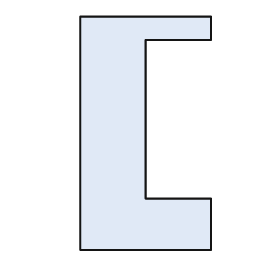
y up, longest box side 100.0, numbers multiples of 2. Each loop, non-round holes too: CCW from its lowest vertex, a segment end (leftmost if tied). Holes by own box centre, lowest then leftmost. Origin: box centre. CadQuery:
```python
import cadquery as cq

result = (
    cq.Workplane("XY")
    .moveTo(-28.0, -50.0)
    .lineTo(28.0, -50.0)
    .lineTo(28.0, -28.0)
    .lineTo(0.0, -28.0)
    .lineTo(0.0, 40.0)
    .lineTo(28.0, 40.0)
    .lineTo(28.0, 50.0)
    .lineTo(-28.0, 50.0)
    .close()
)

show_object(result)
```